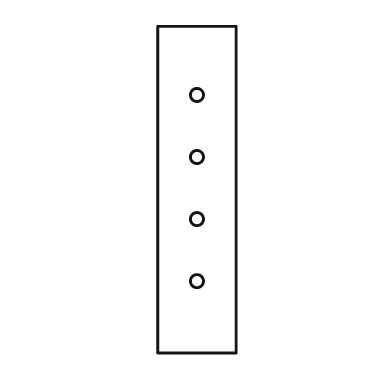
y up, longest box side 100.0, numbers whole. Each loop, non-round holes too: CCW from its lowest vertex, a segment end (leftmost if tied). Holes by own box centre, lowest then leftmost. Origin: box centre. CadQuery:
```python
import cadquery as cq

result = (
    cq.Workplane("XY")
    .moveTo(-12.0, -50.0)
    .lineTo(12.0, -50.0)
    .lineTo(12.0, 50.0)
    .lineTo(-12.0, 50.0)
    .close()
    .moveTo(0.0, -28.0)
    .circle(2.0)
    .moveTo(0.0, -9.0)
    .circle(2.0)
    .moveTo(0.0, 10.0)
    .circle(2.0)
    .moveTo(0.0, 29.0)
    .circle(2.0)
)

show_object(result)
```